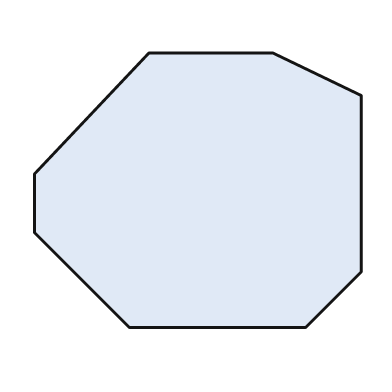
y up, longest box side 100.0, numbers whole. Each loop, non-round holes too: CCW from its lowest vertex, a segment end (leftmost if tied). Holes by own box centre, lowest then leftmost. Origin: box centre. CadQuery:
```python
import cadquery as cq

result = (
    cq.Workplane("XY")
    .moveTo(-21.0, -42.0)
    .lineTo(33.0, -42.0)
    .lineTo(50.0, -25.0)
    .lineTo(50.0, 29.0)
    .lineTo(23.0, 42.0)
    .lineTo(-15.0, 42.0)
    .lineTo(-50.0, 5.0)
    .lineTo(-50.0, -13.0)
    .close()
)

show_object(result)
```